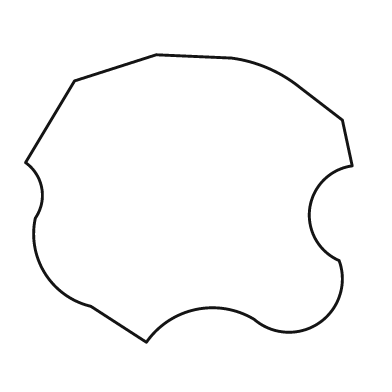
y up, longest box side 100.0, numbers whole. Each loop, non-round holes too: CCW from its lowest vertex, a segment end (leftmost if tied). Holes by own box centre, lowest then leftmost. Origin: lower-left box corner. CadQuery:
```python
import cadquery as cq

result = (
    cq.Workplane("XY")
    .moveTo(37.0, 0.0)
    .threePointArc((52.0, 10.0), (70.0, 7.0))
    .threePointArc((90.0, 6.0), (96.0, 25.0))
    .threePointArc((87.0, 41.0), (100.0, 54.0))
    .lineTo(97.0, 68.0)
    .lineTo(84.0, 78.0)
    .threePointArc((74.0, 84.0), (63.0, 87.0))
    .lineTo(40.0, 88.0)
    .lineTo(15.0, 80.0)
    .lineTo(0.0, 55.0)
    .threePointArc((5.0, 47.0), (3.0, 38.0))
    .threePointArc((6.0, 21.0), (20.0, 11.0))
    .close()
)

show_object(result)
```